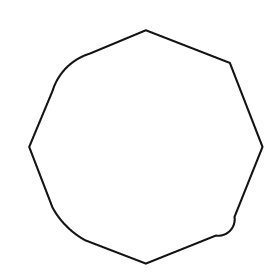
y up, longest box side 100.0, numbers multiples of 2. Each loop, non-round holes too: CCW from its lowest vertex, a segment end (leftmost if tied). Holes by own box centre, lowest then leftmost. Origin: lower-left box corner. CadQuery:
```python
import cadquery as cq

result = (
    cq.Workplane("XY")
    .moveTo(50.0, 0.0)
    .lineTo(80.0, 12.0)
    .threePointArc((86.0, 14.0), (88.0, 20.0))
    .lineTo(100.0, 50.0)
    .lineTo(86.0, 86.0)
    .lineTo(50.0, 100.0)
    .lineTo(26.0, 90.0)
    .threePointArc((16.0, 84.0), (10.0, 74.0))
    .lineTo(0.0, 50.0)
    .lineTo(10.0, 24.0)
    .threePointArc((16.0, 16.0), (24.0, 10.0))
    .close()
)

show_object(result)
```